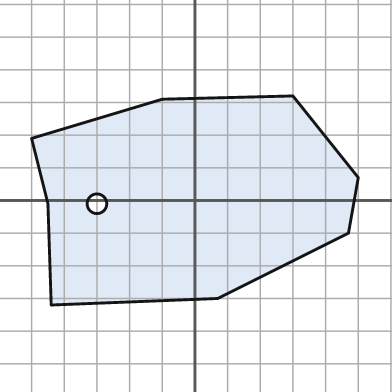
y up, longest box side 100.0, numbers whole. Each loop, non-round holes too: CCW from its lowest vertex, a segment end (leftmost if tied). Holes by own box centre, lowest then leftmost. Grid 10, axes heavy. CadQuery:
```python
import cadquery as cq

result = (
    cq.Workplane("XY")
    .moveTo(-44.0, -32.0)
    .lineTo(7.0, -30.0)
    .lineTo(47.0, -10.0)
    .lineTo(50.0, 7.0)
    .lineTo(30.0, 32.0)
    .lineTo(-10.0, 31.0)
    .lineTo(-50.0, 19.0)
    .lineTo(-45.0, -1.0)
    .close()
    .moveTo(-30.0, -1.0)
    .circle(3.0)
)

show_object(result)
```